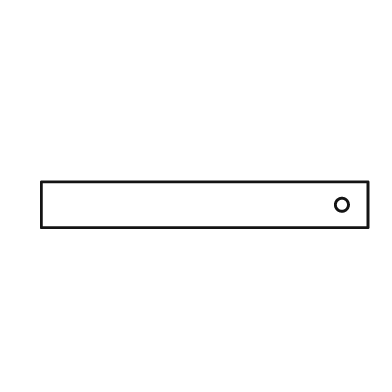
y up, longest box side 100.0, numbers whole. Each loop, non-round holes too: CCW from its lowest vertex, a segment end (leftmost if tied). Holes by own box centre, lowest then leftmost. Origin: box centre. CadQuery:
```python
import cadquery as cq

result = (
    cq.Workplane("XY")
    .moveTo(-50.0, -7.0)
    .lineTo(50.0, -7.0)
    .lineTo(50.0, 7.0)
    .lineTo(-50.0, 7.0)
    .close()
    .moveTo(42.0, 0.0)
    .circle(2.0)
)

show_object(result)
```